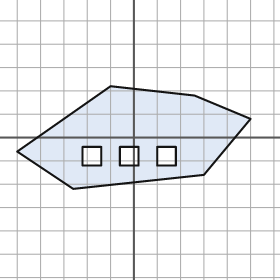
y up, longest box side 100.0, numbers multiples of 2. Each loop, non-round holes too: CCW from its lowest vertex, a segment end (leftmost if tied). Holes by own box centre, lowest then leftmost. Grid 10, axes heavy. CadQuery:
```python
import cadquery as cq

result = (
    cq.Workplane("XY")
    .moveTo(-26.0, -22.0)
    .lineTo(30.0, -16.0)
    .lineTo(50.0, 8.0)
    .lineTo(26.0, 18.0)
    .lineTo(-10.0, 22.0)
    .lineTo(-50.0, -6.0)
    .close()
    .moveTo(-22.0, -12.0)
    .lineTo(-14.0, -12.0)
    .lineTo(-14.0, -4.0)
    .lineTo(-22.0, -4.0)
    .close()
    .moveTo(-6.0, -12.0)
    .lineTo(2.0, -12.0)
    .lineTo(2.0, -4.0)
    .lineTo(-6.0, -4.0)
    .close()
    .moveTo(10.0, -12.0)
    .lineTo(18.0, -12.0)
    .lineTo(18.0, -4.0)
    .lineTo(10.0, -4.0)
    .close()
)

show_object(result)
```